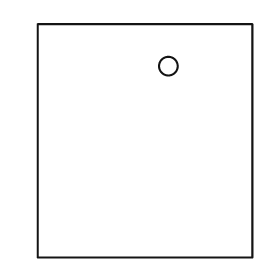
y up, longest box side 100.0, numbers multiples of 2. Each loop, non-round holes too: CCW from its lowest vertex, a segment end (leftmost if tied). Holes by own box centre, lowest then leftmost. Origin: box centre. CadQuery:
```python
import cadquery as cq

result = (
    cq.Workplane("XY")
    .moveTo(-46.0, -50.0)
    .lineTo(46.0, -50.0)
    .lineTo(46.0, 50.0)
    .lineTo(-46.0, 50.0)
    .close()
    .moveTo(10.0, 32.0)
    .circle(4.0)
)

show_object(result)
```